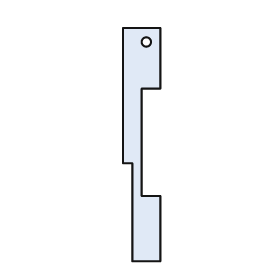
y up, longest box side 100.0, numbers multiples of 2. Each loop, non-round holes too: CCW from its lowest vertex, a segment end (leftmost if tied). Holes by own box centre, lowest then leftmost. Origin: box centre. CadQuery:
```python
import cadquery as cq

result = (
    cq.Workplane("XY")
    .moveTo(-4.0, -50.0)
    .lineTo(8.0, -50.0)
    .lineTo(8.0, -22.0)
    .lineTo(0.0, -22.0)
    .lineTo(0.0, 24.0)
    .lineTo(8.0, 24.0)
    .lineTo(8.0, 50.0)
    .lineTo(-8.0, 50.0)
    .lineTo(-8.0, -8.0)
    .lineTo(-4.0, -8.0)
    .close()
    .moveTo(2.0, 44.0)
    .circle(2.0)
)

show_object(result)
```